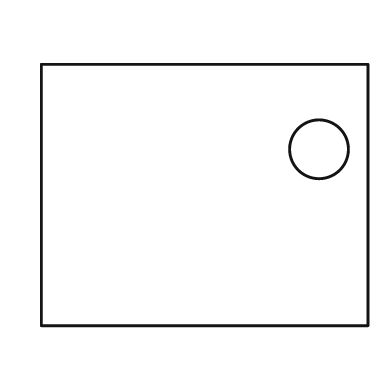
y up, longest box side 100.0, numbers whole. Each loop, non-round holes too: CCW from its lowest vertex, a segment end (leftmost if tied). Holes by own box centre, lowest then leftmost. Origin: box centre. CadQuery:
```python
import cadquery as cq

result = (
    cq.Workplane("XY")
    .moveTo(-50.0, -40.0)
    .lineTo(50.0, -40.0)
    .lineTo(50.0, 40.0)
    .lineTo(-50.0, 40.0)
    .close()
    .moveTo(35.0, 14.0)
    .circle(9.0)
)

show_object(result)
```